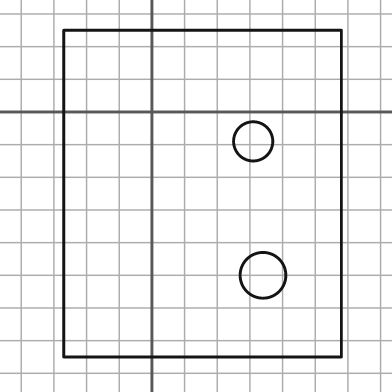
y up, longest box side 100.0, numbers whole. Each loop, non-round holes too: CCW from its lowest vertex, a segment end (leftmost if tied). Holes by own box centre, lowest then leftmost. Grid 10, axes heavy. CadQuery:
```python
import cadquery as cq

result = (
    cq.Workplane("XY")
    .moveTo(-27.0, -75.0)
    .lineTo(58.0, -75.0)
    .lineTo(58.0, 25.0)
    .lineTo(-27.0, 25.0)
    .close()
    .moveTo(34.0, -50.0)
    .circle(7.0)
    .moveTo(31.0, -9.0)
    .circle(6.0)
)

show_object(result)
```